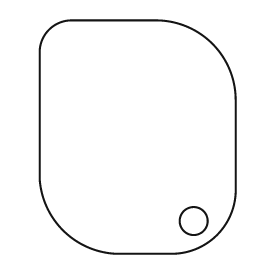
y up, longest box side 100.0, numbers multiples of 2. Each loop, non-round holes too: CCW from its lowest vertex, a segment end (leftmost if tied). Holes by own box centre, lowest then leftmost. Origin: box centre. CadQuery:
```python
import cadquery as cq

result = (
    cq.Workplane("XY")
    .moveTo(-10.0, -50.0)
    .lineTo(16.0, -50.0)
    .threePointArc((34.0, -42.0), (42.0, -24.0))
    .lineTo(42.0, 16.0)
    .threePointArc((32.0, 40.0), (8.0, 50.0))
    .lineTo(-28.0, 50.0)
    .threePointArc((-38.0, 46.0), (-42.0, 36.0))
    .lineTo(-42.0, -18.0)
    .threePointArc((-32.0, -40.0), (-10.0, -50.0))
    .close()
    .moveTo(24.0, -36.0)
    .circle(6.0)
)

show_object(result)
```